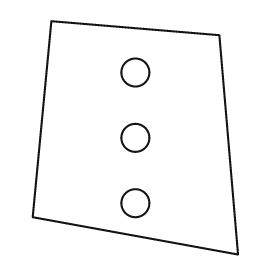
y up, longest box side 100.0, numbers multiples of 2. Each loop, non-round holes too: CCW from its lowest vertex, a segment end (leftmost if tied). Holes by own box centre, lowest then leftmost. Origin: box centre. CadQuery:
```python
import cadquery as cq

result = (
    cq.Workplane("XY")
    .moveTo(44.0, -50.0)
    .lineTo(36.0, 44.0)
    .lineTo(-36.0, 50.0)
    .lineTo(-44.0, -34.0)
    .close()
    .moveTo(0.0, -28.0)
    .circle(6.0)
    .moveTo(0.0, 0.0)
    .circle(6.0)
    .moveTo(0.0, 28.0)
    .circle(6.0)
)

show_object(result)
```